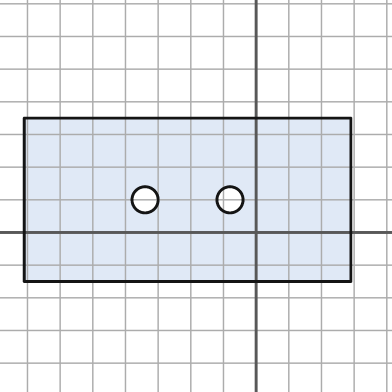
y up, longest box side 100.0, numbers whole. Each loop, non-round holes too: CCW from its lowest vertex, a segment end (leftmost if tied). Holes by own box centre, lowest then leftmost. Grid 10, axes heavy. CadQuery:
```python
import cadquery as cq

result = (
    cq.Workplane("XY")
    .moveTo(-71.0, -15.0)
    .lineTo(29.0, -15.0)
    .lineTo(29.0, 35.0)
    .lineTo(-71.0, 35.0)
    .close()
    .moveTo(-34.0, 10.0)
    .circle(4.0)
    .moveTo(-8.0, 10.0)
    .circle(4.0)
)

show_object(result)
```